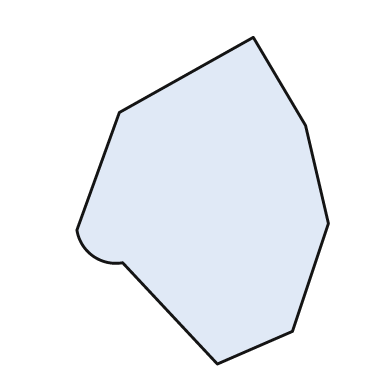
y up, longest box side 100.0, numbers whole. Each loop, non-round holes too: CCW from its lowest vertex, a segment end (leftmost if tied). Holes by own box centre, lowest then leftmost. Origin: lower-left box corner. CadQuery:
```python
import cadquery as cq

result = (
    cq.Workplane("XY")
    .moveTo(43.0, 0.0)
    .lineTo(66.0, 10.0)
    .lineTo(77.0, 43.0)
    .lineTo(70.0, 73.0)
    .lineTo(54.0, 100.0)
    .lineTo(13.0, 77.0)
    .lineTo(0.0, 41.0)
    .threePointArc((5.0, 33.0), (14.0, 31.0))
    .close()
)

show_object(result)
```